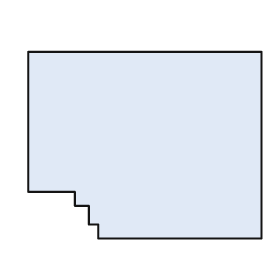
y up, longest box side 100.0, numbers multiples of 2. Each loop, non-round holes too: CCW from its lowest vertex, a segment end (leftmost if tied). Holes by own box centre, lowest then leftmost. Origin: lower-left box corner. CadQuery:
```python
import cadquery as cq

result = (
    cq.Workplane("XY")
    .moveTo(30.0, 0.0)
    .lineTo(100.0, 0.0)
    .lineTo(100.0, 80.0)
    .lineTo(0.0, 80.0)
    .lineTo(0.0, 20.0)
    .lineTo(20.0, 20.0)
    .lineTo(20.0, 14.0)
    .lineTo(26.0, 14.0)
    .lineTo(26.0, 6.0)
    .lineTo(30.0, 6.0)
    .close()
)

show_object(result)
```